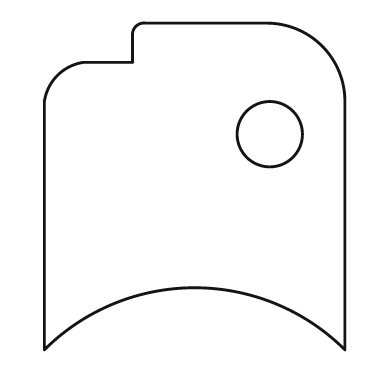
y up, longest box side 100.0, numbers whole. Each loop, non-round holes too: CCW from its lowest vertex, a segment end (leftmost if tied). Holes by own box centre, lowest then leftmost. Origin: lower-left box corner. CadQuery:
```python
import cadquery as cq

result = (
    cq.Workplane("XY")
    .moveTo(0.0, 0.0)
    .threePointArc((46.0, 19.0), (92.0, 0.0))
    .lineTo(92.0, 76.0)
    .threePointArc((85.0, 93.0), (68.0, 100.0))
    .lineTo(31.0, 100.0)
    .threePointArc((28.0, 99.0), (27.0, 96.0))
    .lineTo(27.0, 88.0)
    .lineTo(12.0, 88.0)
    .threePointArc((4.0, 84.0), (0.0, 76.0))
    .close()
    .moveTo(69.0, 66.0)
    .circle(10.0)
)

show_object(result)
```